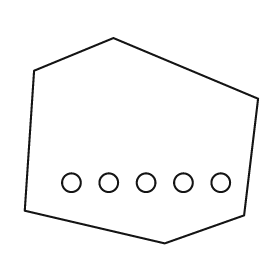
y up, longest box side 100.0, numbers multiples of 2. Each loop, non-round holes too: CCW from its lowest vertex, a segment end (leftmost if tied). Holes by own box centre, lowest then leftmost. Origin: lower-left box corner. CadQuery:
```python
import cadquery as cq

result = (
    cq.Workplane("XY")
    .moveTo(60.0, 0.0)
    .lineTo(94.0, 12.0)
    .lineTo(100.0, 62.0)
    .lineTo(38.0, 88.0)
    .lineTo(4.0, 74.0)
    .lineTo(0.0, 14.0)
    .close()
    .moveTo(20.0, 26.0)
    .circle(4.0)
    .moveTo(36.0, 26.0)
    .circle(4.0)
    .moveTo(52.0, 26.0)
    .circle(4.0)
    .moveTo(68.0, 26.0)
    .circle(4.0)
    .moveTo(84.0, 26.0)
    .circle(4.0)
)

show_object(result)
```